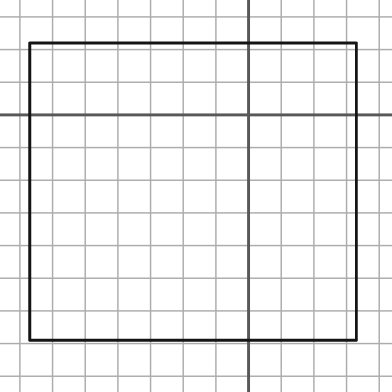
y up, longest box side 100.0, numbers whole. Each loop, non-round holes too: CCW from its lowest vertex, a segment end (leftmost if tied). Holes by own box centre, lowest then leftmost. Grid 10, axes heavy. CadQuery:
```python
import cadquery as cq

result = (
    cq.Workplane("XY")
    .moveTo(-67.0, -69.0)
    .lineTo(33.0, -69.0)
    .lineTo(33.0, 22.0)
    .lineTo(-67.0, 22.0)
    .close()
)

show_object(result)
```